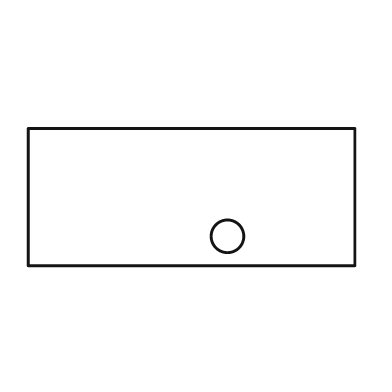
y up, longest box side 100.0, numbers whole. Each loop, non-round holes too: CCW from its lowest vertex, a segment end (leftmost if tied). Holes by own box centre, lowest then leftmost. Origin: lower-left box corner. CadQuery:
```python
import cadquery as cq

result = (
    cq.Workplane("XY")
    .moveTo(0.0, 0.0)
    .lineTo(100.0, 0.0)
    .lineTo(100.0, 42.0)
    .lineTo(0.0, 42.0)
    .close()
    .moveTo(61.0, 9.0)
    .circle(5.0)
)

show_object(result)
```